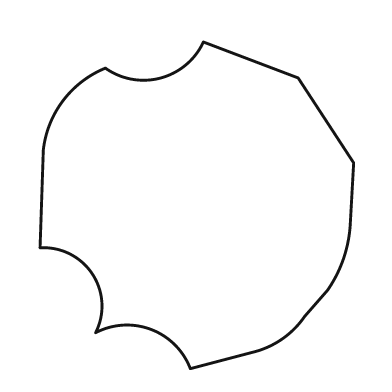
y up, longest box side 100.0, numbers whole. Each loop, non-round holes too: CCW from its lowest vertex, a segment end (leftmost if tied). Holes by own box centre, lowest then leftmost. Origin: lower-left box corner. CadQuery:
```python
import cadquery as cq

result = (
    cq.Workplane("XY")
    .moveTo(46.0, 0.0)
    .lineTo(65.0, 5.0)
    .threePointArc((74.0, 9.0), (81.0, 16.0))
    .lineTo(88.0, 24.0)
    .threePointArc((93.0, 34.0), (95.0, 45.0))
    .lineTo(96.0, 63.0)
    .lineTo(79.0, 89.0)
    .lineTo(50.0, 100.0)
    .threePointArc((37.0, 89.0), (20.0, 92.0))
    .threePointArc((7.0, 82.0), (1.0, 67.0))
    .lineTo(0.0, 37.0)
    .threePointArc((16.0, 29.0), (17.0, 11.0))
    .threePointArc((34.0, 12.0), (46.0, 0.0))
    .close()
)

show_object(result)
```